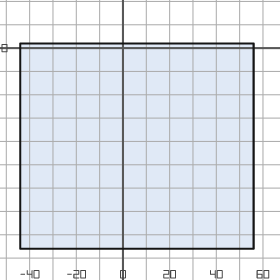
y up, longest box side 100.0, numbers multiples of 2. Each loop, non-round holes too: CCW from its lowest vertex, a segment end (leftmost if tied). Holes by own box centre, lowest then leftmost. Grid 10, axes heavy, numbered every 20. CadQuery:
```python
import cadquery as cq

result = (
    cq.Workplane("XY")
    .moveTo(-44.0, -86.0)
    .lineTo(56.0, -86.0)
    .lineTo(56.0, 2.0)
    .lineTo(-44.0, 2.0)
    .close()
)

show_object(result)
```